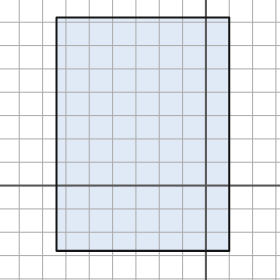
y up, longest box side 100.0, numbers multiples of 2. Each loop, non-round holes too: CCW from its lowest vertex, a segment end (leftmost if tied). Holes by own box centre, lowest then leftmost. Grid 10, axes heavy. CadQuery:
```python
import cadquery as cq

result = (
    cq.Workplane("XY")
    .moveTo(-64.0, -28.0)
    .lineTo(10.0, -28.0)
    .lineTo(10.0, 72.0)
    .lineTo(-64.0, 72.0)
    .close()
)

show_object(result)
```